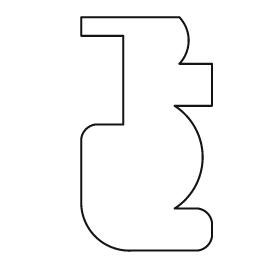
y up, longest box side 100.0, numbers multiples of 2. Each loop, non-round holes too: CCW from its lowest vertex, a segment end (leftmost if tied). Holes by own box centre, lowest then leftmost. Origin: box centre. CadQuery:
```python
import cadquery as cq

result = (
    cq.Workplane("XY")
    .moveTo(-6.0, -50.0)
    .lineTo(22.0, -50.0)
    .threePointArc((26.0, -48.0), (28.0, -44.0))
    .lineTo(28.0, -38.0)
    .threePointArc((26.0, -34.0), (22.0, -32.0))
    .lineTo(12.0, -32.0)
    .threePointArc((24.0, -10.0), (12.0, 12.0))
    .lineTo(28.0, 12.0)
    .lineTo(28.0, 30.0)
    .lineTo(14.0, 30.0)
    .threePointArc((18.0, 40.0), (14.0, 50.0))
    .lineTo(-28.0, 50.0)
    .lineTo(-28.0, 42.0)
    .lineTo(-10.0, 42.0)
    .lineTo(-10.0, 4.0)
    .lineTo(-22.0, 4.0)
    .threePointArc((-26.0, 2.0), (-28.0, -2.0))
    .lineTo(-28.0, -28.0)
    .threePointArc((-22.0, -44.0), (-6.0, -50.0))
    .close()
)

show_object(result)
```